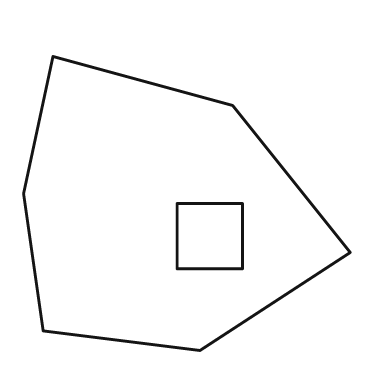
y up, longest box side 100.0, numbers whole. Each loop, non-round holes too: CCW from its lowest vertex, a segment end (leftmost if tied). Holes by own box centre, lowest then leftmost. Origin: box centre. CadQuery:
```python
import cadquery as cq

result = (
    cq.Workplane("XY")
    .moveTo(4.0, -45.0)
    .lineTo(50.0, -15.0)
    .lineTo(14.0, 30.0)
    .lineTo(-41.0, 45.0)
    .lineTo(-50.0, 3.0)
    .lineTo(-44.0, -39.0)
    .close()
    .moveTo(-3.0, -20.0)
    .lineTo(17.0, -20.0)
    .lineTo(17.0, 0.0)
    .lineTo(-3.0, 0.0)
    .close()
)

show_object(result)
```